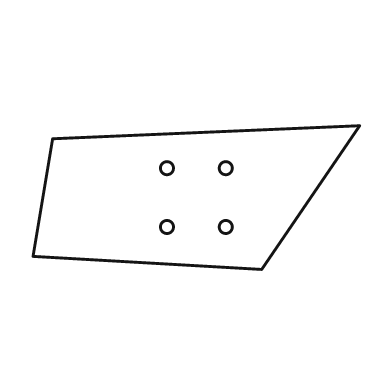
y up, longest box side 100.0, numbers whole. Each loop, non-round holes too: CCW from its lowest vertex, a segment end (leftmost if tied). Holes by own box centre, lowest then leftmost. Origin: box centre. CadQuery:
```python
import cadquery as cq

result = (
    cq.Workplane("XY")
    .moveTo(20.0, -22.0)
    .lineTo(50.0, 22.0)
    .lineTo(-44.0, 18.0)
    .lineTo(-50.0, -18.0)
    .close()
    .moveTo(-9.0, -9.0)
    .circle(2.0)
    .moveTo(9.0, -9.0)
    .circle(2.0)
    .moveTo(-9.0, 9.0)
    .circle(2.0)
    .moveTo(9.0, 9.0)
    .circle(2.0)
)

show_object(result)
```